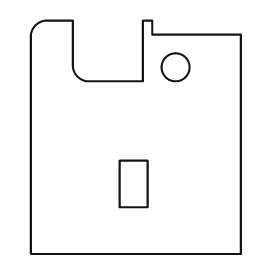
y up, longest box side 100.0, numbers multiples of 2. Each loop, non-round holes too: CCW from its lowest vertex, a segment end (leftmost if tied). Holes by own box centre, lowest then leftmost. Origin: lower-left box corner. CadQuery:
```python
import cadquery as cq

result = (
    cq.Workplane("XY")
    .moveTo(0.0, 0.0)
    .lineTo(90.0, 0.0)
    .lineTo(90.0, 94.0)
    .lineTo(52.0, 94.0)
    .lineTo(52.0, 100.0)
    .lineTo(48.0, 100.0)
    .lineTo(48.0, 74.0)
    .lineTo(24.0, 74.0)
    .threePointArc((20.0, 76.0), (18.0, 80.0))
    .lineTo(18.0, 100.0)
    .lineTo(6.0, 100.0)
    .threePointArc((2.0, 98.0), (0.0, 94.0))
    .close()
    .moveTo(38.0, 20.0)
    .lineTo(50.0, 20.0)
    .lineTo(50.0, 40.0)
    .lineTo(38.0, 40.0)
    .close()
    .moveTo(62.0, 80.0)
    .circle(6.0)
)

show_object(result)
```